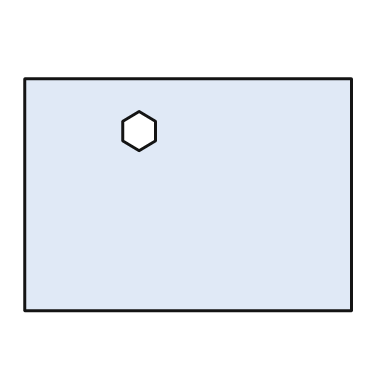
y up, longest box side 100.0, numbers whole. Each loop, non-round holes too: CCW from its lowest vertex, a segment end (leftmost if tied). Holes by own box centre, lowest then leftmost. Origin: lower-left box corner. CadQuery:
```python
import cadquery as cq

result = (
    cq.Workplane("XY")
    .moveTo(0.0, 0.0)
    .lineTo(100.0, 0.0)
    .lineTo(100.0, 71.0)
    .lineTo(0.0, 71.0)
    .close()
    .moveTo(35.0, 49.0)
    .lineTo(40.0, 52.0)
    .lineTo(40.0, 58.0)
    .lineTo(35.0, 61.0)
    .lineTo(30.0, 58.0)
    .lineTo(30.0, 52.0)
    .close()
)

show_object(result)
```